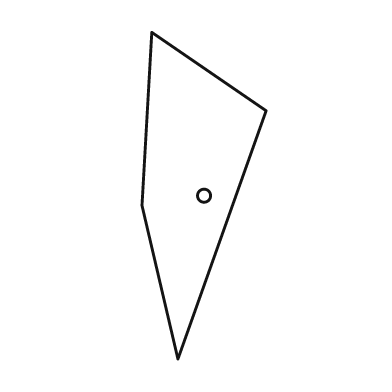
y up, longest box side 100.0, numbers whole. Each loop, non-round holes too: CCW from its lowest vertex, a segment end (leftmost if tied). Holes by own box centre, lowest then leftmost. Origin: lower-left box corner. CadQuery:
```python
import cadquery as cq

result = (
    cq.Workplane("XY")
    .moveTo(11.0, 0.0)
    .lineTo(38.0, 76.0)
    .lineTo(3.0, 100.0)
    .lineTo(0.0, 47.0)
    .close()
    .moveTo(19.0, 50.0)
    .circle(2.0)
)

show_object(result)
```